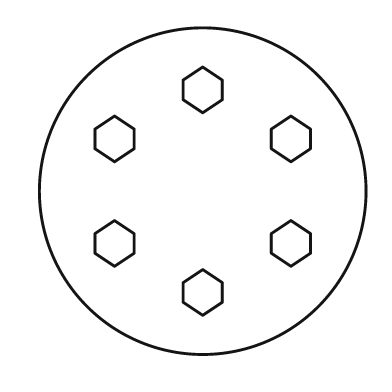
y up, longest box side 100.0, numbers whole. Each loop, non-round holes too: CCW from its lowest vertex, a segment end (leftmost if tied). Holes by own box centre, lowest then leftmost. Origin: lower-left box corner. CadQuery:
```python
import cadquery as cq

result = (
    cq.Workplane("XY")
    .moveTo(50.0, 50.0)
    .circle(50.0)
    .moveTo(50.0, 12.0)
    .lineTo(56.0, 16.0)
    .lineTo(56.0, 22.0)
    .lineTo(50.0, 26.0)
    .lineTo(44.0, 22.0)
    .lineTo(44.0, 16.0)
    .close()
    .moveTo(23.0, 27.0)
    .lineTo(29.0, 31.0)
    .lineTo(29.0, 37.0)
    .lineTo(23.0, 41.0)
    .lineTo(17.0, 37.0)
    .lineTo(17.0, 31.0)
    .close()
    .moveTo(77.0, 27.0)
    .lineTo(83.0, 31.0)
    .lineTo(83.0, 37.0)
    .lineTo(77.0, 41.0)
    .lineTo(71.0, 37.0)
    .lineTo(71.0, 31.0)
    .close()
    .moveTo(23.0, 59.0)
    .lineTo(29.0, 63.0)
    .lineTo(29.0, 69.0)
    .lineTo(23.0, 73.0)
    .lineTo(17.0, 69.0)
    .lineTo(17.0, 63.0)
    .close()
    .moveTo(77.0, 59.0)
    .lineTo(83.0, 63.0)
    .lineTo(83.0, 69.0)
    .lineTo(77.0, 73.0)
    .lineTo(71.0, 69.0)
    .lineTo(71.0, 63.0)
    .close()
    .moveTo(50.0, 74.0)
    .lineTo(56.0, 78.0)
    .lineTo(56.0, 84.0)
    .lineTo(50.0, 88.0)
    .lineTo(44.0, 84.0)
    .lineTo(44.0, 78.0)
    .close()
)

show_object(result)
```